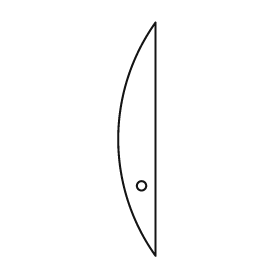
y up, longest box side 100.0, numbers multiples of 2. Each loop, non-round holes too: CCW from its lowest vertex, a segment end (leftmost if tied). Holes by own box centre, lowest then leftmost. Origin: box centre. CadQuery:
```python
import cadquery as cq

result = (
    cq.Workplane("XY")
    .moveTo(8.0, -50.0)
    .lineTo(8.0, 50.0)
    .threePointArc((-8.0, 0.0), (8.0, -50.0))
    .close()
    .moveTo(2.0, -20.0)
    .circle(2.0)
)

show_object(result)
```